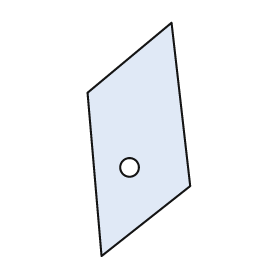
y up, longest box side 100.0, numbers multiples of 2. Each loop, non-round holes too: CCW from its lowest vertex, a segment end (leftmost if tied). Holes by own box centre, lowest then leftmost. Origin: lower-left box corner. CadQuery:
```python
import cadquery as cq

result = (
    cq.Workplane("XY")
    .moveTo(6.0, 0.0)
    .lineTo(44.0, 30.0)
    .lineTo(36.0, 100.0)
    .lineTo(0.0, 70.0)
    .close()
    .moveTo(18.0, 38.0)
    .circle(4.0)
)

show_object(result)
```